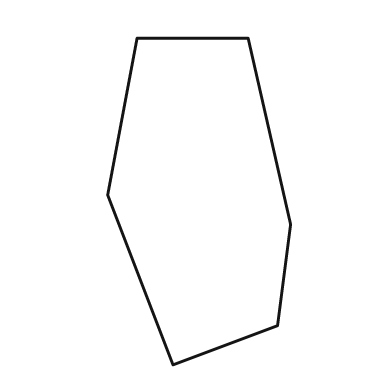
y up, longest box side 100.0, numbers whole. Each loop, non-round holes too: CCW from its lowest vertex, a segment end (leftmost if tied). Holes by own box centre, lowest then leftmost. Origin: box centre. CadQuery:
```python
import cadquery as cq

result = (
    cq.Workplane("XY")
    .moveTo(-8.0, -50.0)
    .lineTo(24.0, -38.0)
    .lineTo(28.0, -7.0)
    .lineTo(15.0, 50.0)
    .lineTo(-19.0, 50.0)
    .lineTo(-28.0, 2.0)
    .close()
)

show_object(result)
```